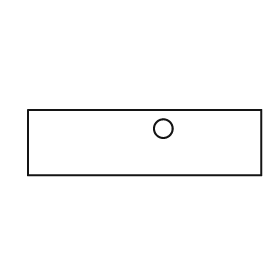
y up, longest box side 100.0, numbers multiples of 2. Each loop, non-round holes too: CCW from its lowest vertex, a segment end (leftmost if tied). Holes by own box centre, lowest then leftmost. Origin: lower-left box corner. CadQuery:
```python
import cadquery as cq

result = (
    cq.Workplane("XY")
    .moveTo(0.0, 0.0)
    .lineTo(100.0, 0.0)
    .lineTo(100.0, 28.0)
    .lineTo(0.0, 28.0)
    .close()
    .moveTo(58.0, 20.0)
    .circle(4.0)
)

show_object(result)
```